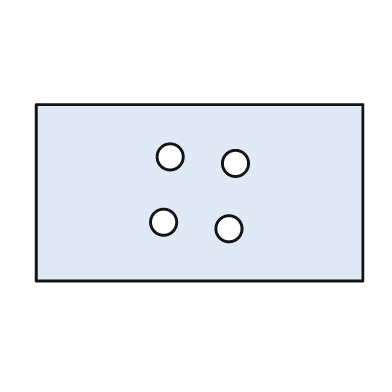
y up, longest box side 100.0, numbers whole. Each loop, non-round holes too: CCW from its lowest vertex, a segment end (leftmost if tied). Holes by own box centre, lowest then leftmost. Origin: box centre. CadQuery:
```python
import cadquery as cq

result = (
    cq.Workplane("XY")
    .moveTo(-50.0, -27.0)
    .lineTo(50.0, -27.0)
    .lineTo(50.0, 27.0)
    .lineTo(-50.0, 27.0)
    .close()
    .moveTo(9.0, -11.0)
    .circle(4.0)
    .moveTo(-11.0, -9.0)
    .circle(4.0)
    .moveTo(11.0, 9.0)
    .circle(4.0)
    .moveTo(-9.0, 11.0)
    .circle(4.0)
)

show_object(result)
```